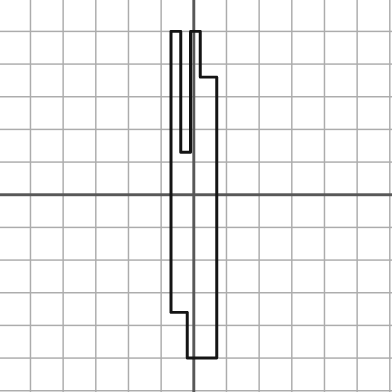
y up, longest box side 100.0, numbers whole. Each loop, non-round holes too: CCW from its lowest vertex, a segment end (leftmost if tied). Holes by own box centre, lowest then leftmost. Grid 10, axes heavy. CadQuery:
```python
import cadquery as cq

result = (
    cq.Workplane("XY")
    .moveTo(-2.0, -50.0)
    .lineTo(7.0, -50.0)
    .lineTo(7.0, 36.0)
    .lineTo(2.0, 36.0)
    .lineTo(2.0, 50.0)
    .lineTo(-1.0, 50.0)
    .lineTo(-1.0, 13.0)
    .lineTo(-4.0, 13.0)
    .lineTo(-4.0, 50.0)
    .lineTo(-7.0, 50.0)
    .lineTo(-7.0, -36.0)
    .lineTo(-2.0, -36.0)
    .close()
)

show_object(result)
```